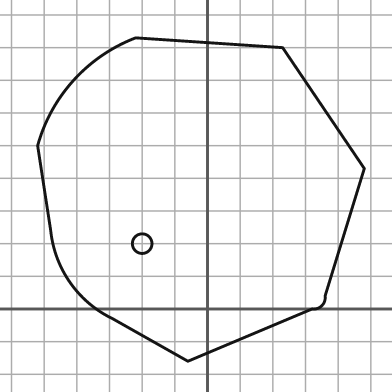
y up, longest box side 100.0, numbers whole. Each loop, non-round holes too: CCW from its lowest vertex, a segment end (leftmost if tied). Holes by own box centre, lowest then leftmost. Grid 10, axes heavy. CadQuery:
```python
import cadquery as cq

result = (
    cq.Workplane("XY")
    .moveTo(-6.0, -16.0)
    .lineTo(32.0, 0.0)
    .threePointArc((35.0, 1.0), (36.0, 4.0))
    .lineTo(48.0, 43.0)
    .lineTo(23.0, 80.0)
    .lineTo(-22.0, 83.0)
    .threePointArc((-41.0, 70.0), (-52.0, 50.0))
    .lineTo(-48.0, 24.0)
    .threePointArc((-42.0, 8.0), (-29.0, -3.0))
    .close()
    .moveTo(-20.0, 20.0)
    .circle(3.0)
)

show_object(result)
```